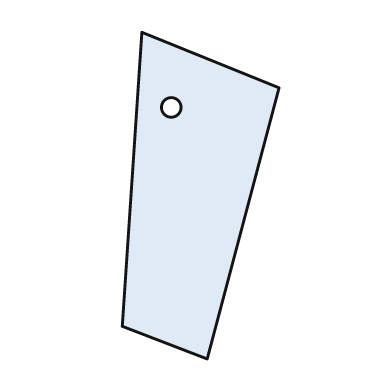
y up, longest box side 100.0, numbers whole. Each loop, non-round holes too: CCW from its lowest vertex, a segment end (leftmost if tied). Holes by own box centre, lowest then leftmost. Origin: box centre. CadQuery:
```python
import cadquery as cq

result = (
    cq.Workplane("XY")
    .moveTo(2.0, -50.0)
    .lineTo(24.0, 33.0)
    .lineTo(-18.0, 50.0)
    .lineTo(-24.0, -40.0)
    .close()
    .moveTo(-9.0, 27.0)
    .circle(3.0)
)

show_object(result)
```